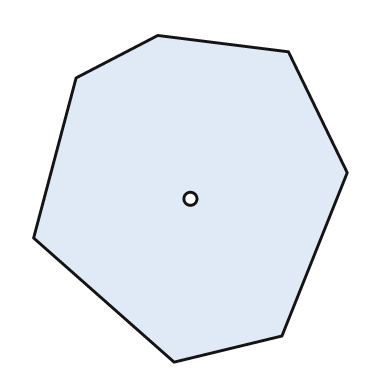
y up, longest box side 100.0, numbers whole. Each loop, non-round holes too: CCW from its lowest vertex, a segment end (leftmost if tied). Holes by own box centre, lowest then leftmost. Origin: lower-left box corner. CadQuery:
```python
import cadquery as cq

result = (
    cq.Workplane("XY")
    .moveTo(43.0, 0.0)
    .lineTo(76.0, 8.0)
    .lineTo(96.0, 58.0)
    .lineTo(78.0, 95.0)
    .lineTo(38.0, 100.0)
    .lineTo(13.0, 87.0)
    .lineTo(0.0, 38.0)
    .close()
    .moveTo(48.0, 50.0)
    .circle(2.0)
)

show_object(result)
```